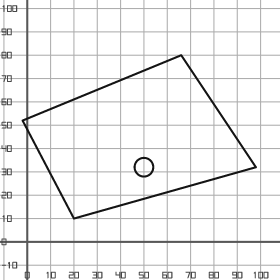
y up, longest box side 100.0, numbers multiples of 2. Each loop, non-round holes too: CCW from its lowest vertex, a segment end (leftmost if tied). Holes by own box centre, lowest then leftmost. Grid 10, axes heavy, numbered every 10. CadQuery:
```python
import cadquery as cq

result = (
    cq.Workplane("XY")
    .moveTo(20.0, 10.0)
    .lineTo(98.0, 32.0)
    .lineTo(66.0, 80.0)
    .lineTo(-2.0, 52.0)
    .close()
    .moveTo(50.0, 32.0)
    .circle(4.0)
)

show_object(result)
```